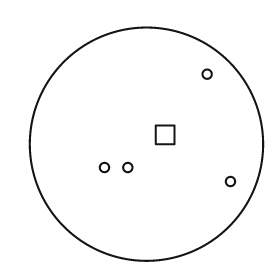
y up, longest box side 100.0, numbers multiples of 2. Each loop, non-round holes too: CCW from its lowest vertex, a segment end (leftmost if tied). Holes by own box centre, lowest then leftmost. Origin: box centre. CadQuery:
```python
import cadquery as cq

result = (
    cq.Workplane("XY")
    .moveTo(0.0, 0.0)
    .circle(50.0)
    .moveTo(36.0, -16.0)
    .circle(2.0)
    .moveTo(-18.0, -10.0)
    .circle(2.0)
    .moveTo(-8.0, -10.0)
    .circle(2.0)
    .moveTo(4.0, 0.0)
    .lineTo(12.0, 0.0)
    .lineTo(12.0, 8.0)
    .lineTo(4.0, 8.0)
    .close()
    .moveTo(26.0, 30.0)
    .circle(2.0)
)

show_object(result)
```